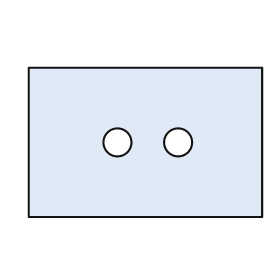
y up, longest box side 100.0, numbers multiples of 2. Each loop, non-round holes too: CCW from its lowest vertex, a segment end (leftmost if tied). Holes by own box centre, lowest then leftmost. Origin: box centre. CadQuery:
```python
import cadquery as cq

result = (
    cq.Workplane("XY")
    .moveTo(-50.0, -32.0)
    .lineTo(50.0, -32.0)
    .lineTo(50.0, 32.0)
    .lineTo(-50.0, 32.0)
    .close()
    .moveTo(-12.0, 0.0)
    .circle(6.0)
    .moveTo(14.0, 0.0)
    .circle(6.0)
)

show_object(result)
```